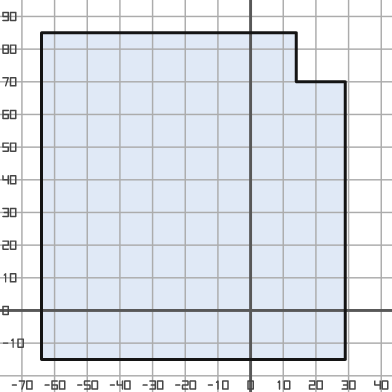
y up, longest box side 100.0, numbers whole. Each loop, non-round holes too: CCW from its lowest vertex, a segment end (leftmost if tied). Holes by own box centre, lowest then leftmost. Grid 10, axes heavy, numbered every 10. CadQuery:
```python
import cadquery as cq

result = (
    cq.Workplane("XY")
    .moveTo(-64.0, -15.0)
    .lineTo(29.0, -15.0)
    .lineTo(29.0, 70.0)
    .lineTo(14.0, 70.0)
    .lineTo(14.0, 85.0)
    .lineTo(-64.0, 85.0)
    .close()
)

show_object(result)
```